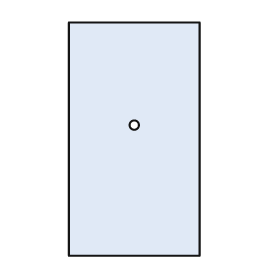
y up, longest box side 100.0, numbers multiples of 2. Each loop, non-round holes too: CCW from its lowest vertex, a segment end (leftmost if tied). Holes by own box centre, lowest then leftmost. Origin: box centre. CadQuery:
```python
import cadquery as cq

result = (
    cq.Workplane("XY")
    .moveTo(-28.0, -50.0)
    .lineTo(28.0, -50.0)
    .lineTo(28.0, 50.0)
    .lineTo(-28.0, 50.0)
    .close()
    .moveTo(0.0, 6.0)
    .circle(2.0)
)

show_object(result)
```